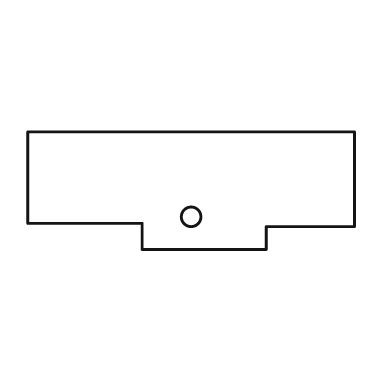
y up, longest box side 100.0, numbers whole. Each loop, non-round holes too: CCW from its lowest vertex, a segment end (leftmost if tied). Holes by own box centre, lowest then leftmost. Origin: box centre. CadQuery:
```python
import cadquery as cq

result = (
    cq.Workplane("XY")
    .moveTo(-15.0, -18.0)
    .lineTo(23.0, -18.0)
    .lineTo(23.0, -11.0)
    .lineTo(50.0, -11.0)
    .lineTo(50.0, 18.0)
    .lineTo(-50.0, 18.0)
    .lineTo(-50.0, -10.0)
    .lineTo(-15.0, -10.0)
    .close()
    .moveTo(0.0, -8.0)
    .circle(3.0)
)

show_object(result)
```